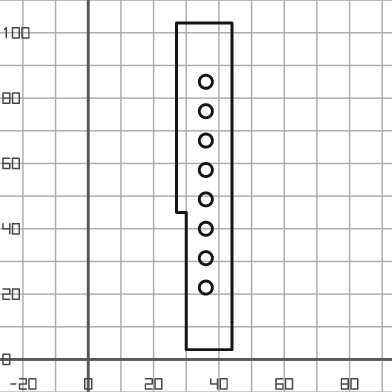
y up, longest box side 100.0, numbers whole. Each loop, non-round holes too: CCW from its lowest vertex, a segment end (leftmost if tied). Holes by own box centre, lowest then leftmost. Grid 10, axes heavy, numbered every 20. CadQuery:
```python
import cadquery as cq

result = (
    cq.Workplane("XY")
    .moveTo(30.0, 3.0)
    .lineTo(44.0, 3.0)
    .lineTo(44.0, 103.0)
    .lineTo(27.0, 103.0)
    .lineTo(27.0, 45.0)
    .lineTo(30.0, 45.0)
    .close()
    .moveTo(36.0, 22.0)
    .circle(2.0)
    .moveTo(36.0, 31.0)
    .circle(2.0)
    .moveTo(36.0, 40.0)
    .circle(2.0)
    .moveTo(36.0, 49.0)
    .circle(2.0)
    .moveTo(36.0, 58.0)
    .circle(2.0)
    .moveTo(36.0, 67.0)
    .circle(2.0)
    .moveTo(36.0, 76.0)
    .circle(2.0)
    .moveTo(36.0, 85.0)
    .circle(2.0)
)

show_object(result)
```